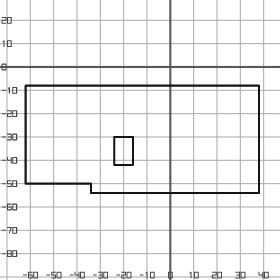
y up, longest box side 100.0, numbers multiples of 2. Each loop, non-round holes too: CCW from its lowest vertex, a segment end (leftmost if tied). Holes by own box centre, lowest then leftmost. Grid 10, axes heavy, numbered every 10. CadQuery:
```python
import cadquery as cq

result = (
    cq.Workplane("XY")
    .moveTo(-34.0, -54.0)
    .lineTo(38.0, -54.0)
    .lineTo(38.0, -8.0)
    .lineTo(-62.0, -8.0)
    .lineTo(-62.0, -50.0)
    .lineTo(-34.0, -50.0)
    .close()
    .moveTo(-24.0, -42.0)
    .lineTo(-16.0, -42.0)
    .lineTo(-16.0, -30.0)
    .lineTo(-24.0, -30.0)
    .close()
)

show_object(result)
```